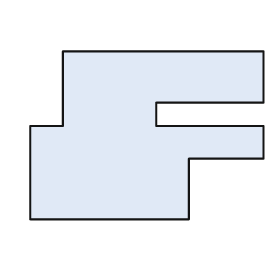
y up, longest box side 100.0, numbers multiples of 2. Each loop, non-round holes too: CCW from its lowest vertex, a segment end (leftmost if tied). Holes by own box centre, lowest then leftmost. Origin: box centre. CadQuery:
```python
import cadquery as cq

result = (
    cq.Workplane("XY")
    .moveTo(-50.0, -36.0)
    .lineTo(18.0, -36.0)
    .lineTo(18.0, -10.0)
    .lineTo(50.0, -10.0)
    .lineTo(50.0, 4.0)
    .lineTo(4.0, 4.0)
    .lineTo(4.0, 14.0)
    .lineTo(50.0, 14.0)
    .lineTo(50.0, 36.0)
    .lineTo(-36.0, 36.0)
    .lineTo(-36.0, 4.0)
    .lineTo(-50.0, 4.0)
    .close()
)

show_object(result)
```